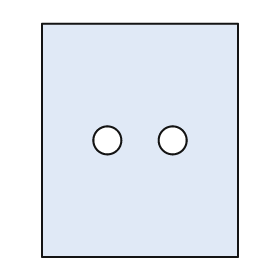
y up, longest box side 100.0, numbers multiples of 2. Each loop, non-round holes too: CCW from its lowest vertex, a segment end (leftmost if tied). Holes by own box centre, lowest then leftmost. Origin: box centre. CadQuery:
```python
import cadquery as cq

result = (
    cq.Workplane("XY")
    .moveTo(-42.0, -50.0)
    .lineTo(42.0, -50.0)
    .lineTo(42.0, 50.0)
    .lineTo(-42.0, 50.0)
    .close()
    .moveTo(-14.0, 0.0)
    .circle(6.0)
    .moveTo(14.0, 0.0)
    .circle(6.0)
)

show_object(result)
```